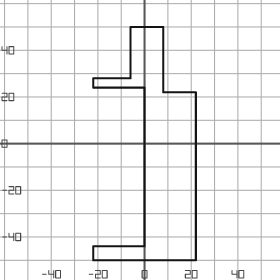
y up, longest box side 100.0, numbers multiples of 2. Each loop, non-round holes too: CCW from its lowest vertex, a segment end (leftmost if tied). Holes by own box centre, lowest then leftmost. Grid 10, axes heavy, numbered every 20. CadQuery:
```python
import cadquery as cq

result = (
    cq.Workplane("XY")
    .moveTo(-22.0, -50.0)
    .lineTo(22.0, -50.0)
    .lineTo(22.0, 22.0)
    .lineTo(8.0, 22.0)
    .lineTo(8.0, 50.0)
    .lineTo(-6.0, 50.0)
    .lineTo(-6.0, 28.0)
    .lineTo(-22.0, 28.0)
    .lineTo(-22.0, 24.0)
    .lineTo(0.0, 24.0)
    .lineTo(0.0, -44.0)
    .lineTo(-22.0, -44.0)
    .close()
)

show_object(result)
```